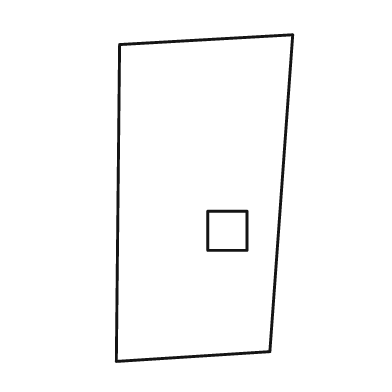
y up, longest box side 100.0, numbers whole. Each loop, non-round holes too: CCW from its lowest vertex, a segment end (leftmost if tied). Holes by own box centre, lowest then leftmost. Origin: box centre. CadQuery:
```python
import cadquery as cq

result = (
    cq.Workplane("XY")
    .moveTo(-27.0, -50.0)
    .lineTo(20.0, -47.0)
    .lineTo(27.0, 50.0)
    .lineTo(-26.0, 47.0)
    .close()
    .moveTo(1.0, -16.0)
    .lineTo(13.0, -16.0)
    .lineTo(13.0, -4.0)
    .lineTo(1.0, -4.0)
    .close()
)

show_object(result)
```